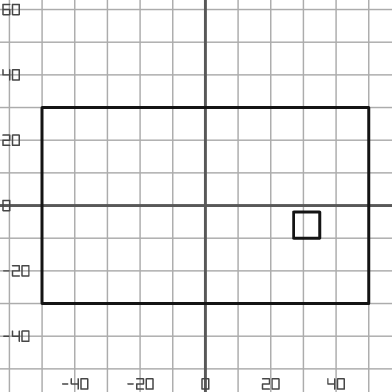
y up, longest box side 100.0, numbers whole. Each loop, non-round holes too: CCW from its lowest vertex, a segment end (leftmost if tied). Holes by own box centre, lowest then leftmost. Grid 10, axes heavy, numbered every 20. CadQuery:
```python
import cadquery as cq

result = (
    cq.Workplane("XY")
    .moveTo(-50.0, -30.0)
    .lineTo(50.0, -30.0)
    .lineTo(50.0, 30.0)
    .lineTo(-50.0, 30.0)
    .close()
    .moveTo(27.0, -10.0)
    .lineTo(35.0, -10.0)
    .lineTo(35.0, -2.0)
    .lineTo(27.0, -2.0)
    .close()
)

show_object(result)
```